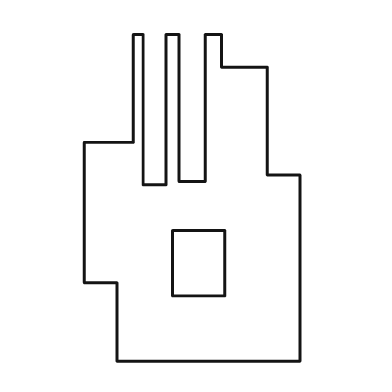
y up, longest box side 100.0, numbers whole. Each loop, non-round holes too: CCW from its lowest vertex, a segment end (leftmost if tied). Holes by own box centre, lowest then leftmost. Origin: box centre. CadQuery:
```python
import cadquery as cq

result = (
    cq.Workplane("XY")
    .moveTo(-23.0, -50.0)
    .lineTo(33.0, -50.0)
    .lineTo(33.0, 7.0)
    .lineTo(23.0, 7.0)
    .lineTo(23.0, 40.0)
    .lineTo(9.0, 40.0)
    .lineTo(9.0, 50.0)
    .lineTo(4.0, 50.0)
    .lineTo(4.0, 5.0)
    .lineTo(-4.0, 5.0)
    .lineTo(-4.0, 50.0)
    .lineTo(-8.0, 50.0)
    .lineTo(-8.0, 4.0)
    .lineTo(-15.0, 4.0)
    .lineTo(-15.0, 50.0)
    .lineTo(-18.0, 50.0)
    .lineTo(-18.0, 17.0)
    .lineTo(-33.0, 17.0)
    .lineTo(-33.0, -26.0)
    .lineTo(-23.0, -26.0)
    .close()
    .moveTo(-6.0, -30.0)
    .lineTo(10.0, -30.0)
    .lineTo(10.0, -10.0)
    .lineTo(-6.0, -10.0)
    .close()
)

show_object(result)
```